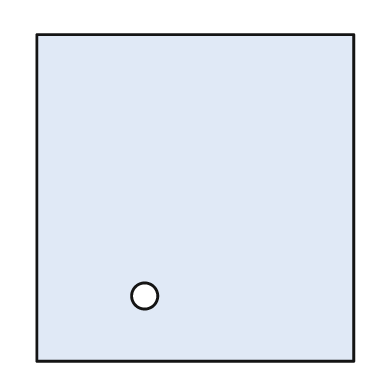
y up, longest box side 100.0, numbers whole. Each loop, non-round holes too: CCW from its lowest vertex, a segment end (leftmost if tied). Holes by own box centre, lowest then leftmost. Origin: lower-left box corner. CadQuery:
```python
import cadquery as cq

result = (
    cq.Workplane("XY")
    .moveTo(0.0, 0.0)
    .lineTo(97.0, 0.0)
    .lineTo(97.0, 100.0)
    .lineTo(0.0, 100.0)
    .close()
    .moveTo(33.0, 20.0)
    .circle(4.0)
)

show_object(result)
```